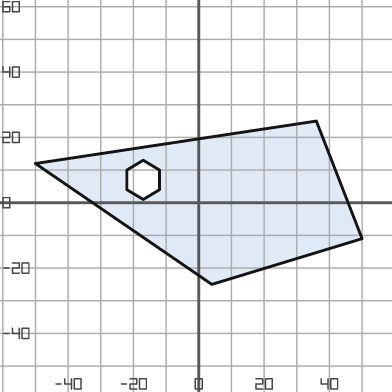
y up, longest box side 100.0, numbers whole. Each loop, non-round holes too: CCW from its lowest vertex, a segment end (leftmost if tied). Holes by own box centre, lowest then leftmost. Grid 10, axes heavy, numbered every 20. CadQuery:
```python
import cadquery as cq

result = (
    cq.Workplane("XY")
    .moveTo(4.0, -25.0)
    .lineTo(50.0, -11.0)
    .lineTo(36.0, 25.0)
    .lineTo(-50.0, 12.0)
    .close()
    .moveTo(-17.0, 1.0)
    .lineTo(-12.0, 4.0)
    .lineTo(-12.0, 10.0)
    .lineTo(-17.0, 13.0)
    .lineTo(-22.0, 10.0)
    .lineTo(-22.0, 4.0)
    .close()
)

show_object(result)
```